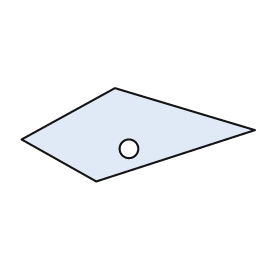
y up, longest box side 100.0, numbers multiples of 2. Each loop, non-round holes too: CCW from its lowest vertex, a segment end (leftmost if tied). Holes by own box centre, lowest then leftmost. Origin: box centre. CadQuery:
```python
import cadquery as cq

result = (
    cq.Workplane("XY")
    .moveTo(-18.0, -20.0)
    .lineTo(50.0, 2.0)
    .lineTo(-10.0, 20.0)
    .lineTo(-50.0, -2.0)
    .close()
    .moveTo(-4.0, -6.0)
    .circle(4.0)
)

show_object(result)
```